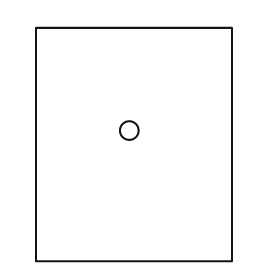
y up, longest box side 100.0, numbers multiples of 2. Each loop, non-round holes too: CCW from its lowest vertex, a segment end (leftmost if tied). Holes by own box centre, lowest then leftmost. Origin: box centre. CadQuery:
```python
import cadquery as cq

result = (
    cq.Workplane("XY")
    .moveTo(-42.0, -50.0)
    .lineTo(42.0, -50.0)
    .lineTo(42.0, 50.0)
    .lineTo(-42.0, 50.0)
    .close()
    .moveTo(-2.0, 6.0)
    .circle(4.0)
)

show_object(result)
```